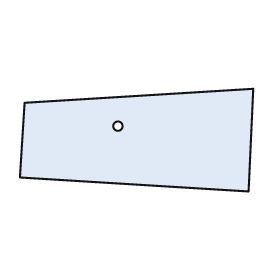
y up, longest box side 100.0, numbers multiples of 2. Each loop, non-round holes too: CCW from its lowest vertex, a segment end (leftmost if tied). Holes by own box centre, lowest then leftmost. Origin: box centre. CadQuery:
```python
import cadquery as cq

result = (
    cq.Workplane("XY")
    .moveTo(48.0, -22.0)
    .lineTo(50.0, 22.0)
    .lineTo(-48.0, 16.0)
    .lineTo(-50.0, -16.0)
    .close()
    .moveTo(-8.0, 6.0)
    .circle(2.0)
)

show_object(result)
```